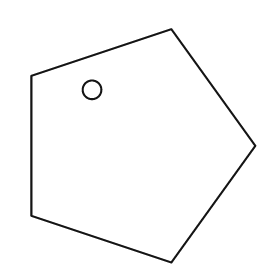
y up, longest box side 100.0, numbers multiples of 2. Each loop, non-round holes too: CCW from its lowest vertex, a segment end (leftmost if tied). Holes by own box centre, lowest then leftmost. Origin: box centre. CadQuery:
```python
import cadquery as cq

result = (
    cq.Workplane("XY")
    .moveTo(12.0, -50.0)
    .lineTo(48.0, 0.0)
    .lineTo(12.0, 50.0)
    .lineTo(-48.0, 30.0)
    .lineTo(-48.0, -30.0)
    .close()
    .moveTo(-22.0, 24.0)
    .circle(4.0)
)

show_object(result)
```